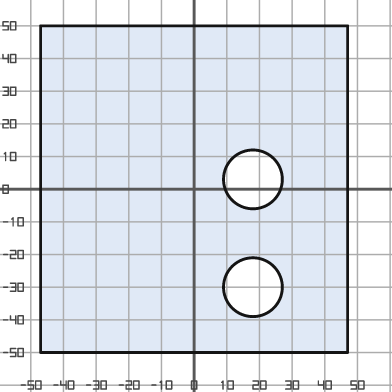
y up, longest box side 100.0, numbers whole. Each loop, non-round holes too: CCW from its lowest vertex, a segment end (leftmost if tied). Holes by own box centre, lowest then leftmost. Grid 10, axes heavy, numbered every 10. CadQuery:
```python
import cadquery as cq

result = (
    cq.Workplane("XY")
    .moveTo(-47.0, -50.0)
    .lineTo(47.0, -50.0)
    .lineTo(47.0, 50.0)
    .lineTo(-47.0, 50.0)
    .close()
    .moveTo(18.0, -30.0)
    .circle(9.0)
    .moveTo(18.0, 3.0)
    .circle(9.0)
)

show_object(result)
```